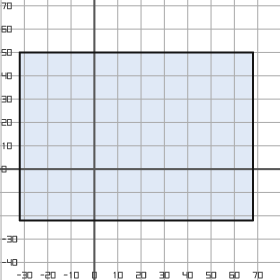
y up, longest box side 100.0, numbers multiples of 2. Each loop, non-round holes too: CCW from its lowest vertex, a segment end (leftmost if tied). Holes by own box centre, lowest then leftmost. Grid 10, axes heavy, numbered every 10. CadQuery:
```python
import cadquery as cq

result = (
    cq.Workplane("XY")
    .moveTo(-32.0, -22.0)
    .lineTo(68.0, -22.0)
    .lineTo(68.0, 50.0)
    .lineTo(-32.0, 50.0)
    .close()
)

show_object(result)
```